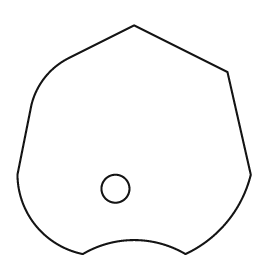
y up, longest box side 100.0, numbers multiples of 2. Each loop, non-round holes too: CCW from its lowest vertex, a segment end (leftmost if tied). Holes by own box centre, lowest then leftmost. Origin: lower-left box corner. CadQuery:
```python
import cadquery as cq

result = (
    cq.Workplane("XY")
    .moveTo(28.0, 0.0)
    .threePointArc((50.0, 6.0), (72.0, 0.0))
    .threePointArc((90.0, 14.0), (100.0, 34.0))
    .lineTo(90.0, 78.0)
    .lineTo(50.0, 98.0)
    .lineTo(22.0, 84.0)
    .threePointArc((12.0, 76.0), (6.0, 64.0))
    .lineTo(0.0, 34.0)
    .threePointArc((8.0, 12.0), (28.0, 0.0))
    .close()
    .moveTo(42.0, 28.0)
    .circle(6.0)
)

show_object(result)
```